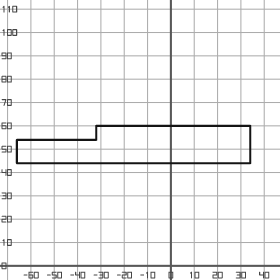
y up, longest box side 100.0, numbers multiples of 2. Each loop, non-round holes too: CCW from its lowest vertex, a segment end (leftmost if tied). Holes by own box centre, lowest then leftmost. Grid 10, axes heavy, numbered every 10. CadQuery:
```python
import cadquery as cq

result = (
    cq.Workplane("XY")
    .moveTo(-66.0, 44.0)
    .lineTo(34.0, 44.0)
    .lineTo(34.0, 60.0)
    .lineTo(-32.0, 60.0)
    .lineTo(-32.0, 54.0)
    .lineTo(-66.0, 54.0)
    .close()
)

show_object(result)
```